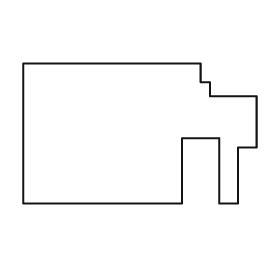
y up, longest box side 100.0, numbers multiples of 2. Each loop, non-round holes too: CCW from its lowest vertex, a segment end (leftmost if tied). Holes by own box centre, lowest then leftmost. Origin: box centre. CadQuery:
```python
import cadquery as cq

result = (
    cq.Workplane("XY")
    .moveTo(-50.0, -30.0)
    .lineTo(18.0, -30.0)
    .lineTo(18.0, -2.0)
    .lineTo(34.0, -2.0)
    .lineTo(34.0, -30.0)
    .lineTo(42.0, -30.0)
    .lineTo(42.0, -6.0)
    .lineTo(50.0, -6.0)
    .lineTo(50.0, 16.0)
    .lineTo(30.0, 16.0)
    .lineTo(30.0, 22.0)
    .lineTo(26.0, 22.0)
    .lineTo(26.0, 30.0)
    .lineTo(-50.0, 30.0)
    .close()
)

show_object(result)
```